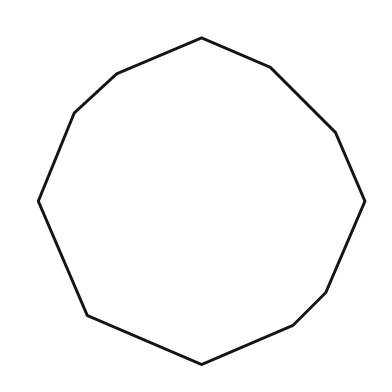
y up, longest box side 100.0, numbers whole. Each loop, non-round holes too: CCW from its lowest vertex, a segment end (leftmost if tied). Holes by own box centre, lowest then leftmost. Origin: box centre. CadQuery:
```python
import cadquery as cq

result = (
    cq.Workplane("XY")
    .moveTo(0.0, -50.0)
    .lineTo(28.0, -38.0)
    .lineTo(38.0, -28.0)
    .lineTo(50.0, 0.0)
    .lineTo(41.0, 21.0)
    .lineTo(21.0, 41.0)
    .lineTo(0.0, 50.0)
    .lineTo(-26.0, 39.0)
    .lineTo(-39.0, 27.0)
    .lineTo(-50.0, 0.0)
    .lineTo(-35.0, -35.0)
    .close()
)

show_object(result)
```